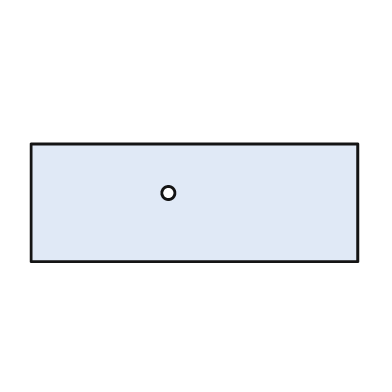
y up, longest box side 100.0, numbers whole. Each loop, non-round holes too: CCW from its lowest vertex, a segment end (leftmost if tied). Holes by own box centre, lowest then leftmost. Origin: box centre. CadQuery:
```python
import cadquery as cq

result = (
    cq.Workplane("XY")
    .moveTo(-50.0, -18.0)
    .lineTo(50.0, -18.0)
    .lineTo(50.0, 18.0)
    .lineTo(-50.0, 18.0)
    .close()
    .moveTo(-8.0, 3.0)
    .circle(2.0)
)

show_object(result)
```